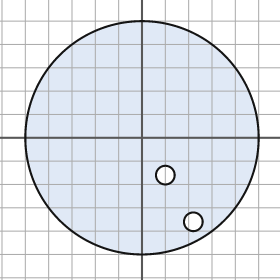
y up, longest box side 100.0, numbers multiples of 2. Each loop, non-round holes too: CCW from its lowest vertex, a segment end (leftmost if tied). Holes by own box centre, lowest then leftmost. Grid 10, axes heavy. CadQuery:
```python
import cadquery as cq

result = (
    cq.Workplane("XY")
    .moveTo(0.0, 0.0)
    .circle(50.0)
    .moveTo(22.0, -36.0)
    .circle(4.0)
    .moveTo(10.0, -16.0)
    .circle(4.0)
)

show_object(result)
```